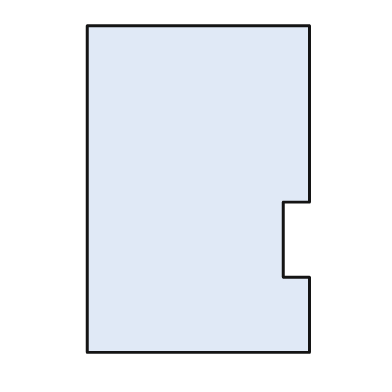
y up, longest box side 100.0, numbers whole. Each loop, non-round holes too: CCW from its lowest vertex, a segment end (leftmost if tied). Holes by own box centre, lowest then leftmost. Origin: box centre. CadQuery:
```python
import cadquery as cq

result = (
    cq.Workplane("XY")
    .moveTo(-34.0, -50.0)
    .lineTo(34.0, -50.0)
    .lineTo(34.0, -27.0)
    .lineTo(26.0, -27.0)
    .lineTo(26.0, -4.0)
    .lineTo(34.0, -4.0)
    .lineTo(34.0, 50.0)
    .lineTo(-34.0, 50.0)
    .close()
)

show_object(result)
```